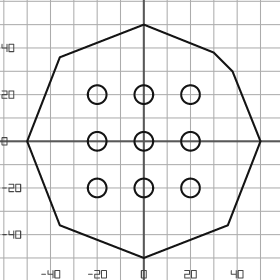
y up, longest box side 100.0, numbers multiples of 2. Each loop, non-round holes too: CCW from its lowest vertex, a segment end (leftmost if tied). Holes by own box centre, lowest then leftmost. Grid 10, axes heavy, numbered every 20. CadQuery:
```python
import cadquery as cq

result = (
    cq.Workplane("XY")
    .moveTo(0.0, -50.0)
    .lineTo(36.0, -36.0)
    .lineTo(50.0, 0.0)
    .lineTo(38.0, 30.0)
    .lineTo(30.0, 38.0)
    .lineTo(0.0, 50.0)
    .lineTo(-36.0, 36.0)
    .lineTo(-50.0, 0.0)
    .lineTo(-36.0, -36.0)
    .close()
    .moveTo(-20.0, -20.0)
    .circle(4.0)
    .moveTo(0.0, -20.0)
    .circle(4.0)
    .moveTo(20.0, -20.0)
    .circle(4.0)
    .moveTo(-20.0, 0.0)
    .circle(4.0)
    .moveTo(0.0, 0.0)
    .circle(4.0)
    .moveTo(20.0, 0.0)
    .circle(4.0)
    .moveTo(-20.0, 20.0)
    .circle(4.0)
    .moveTo(0.0, 20.0)
    .circle(4.0)
    .moveTo(20.0, 20.0)
    .circle(4.0)
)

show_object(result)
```